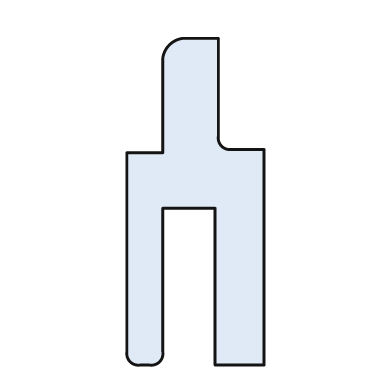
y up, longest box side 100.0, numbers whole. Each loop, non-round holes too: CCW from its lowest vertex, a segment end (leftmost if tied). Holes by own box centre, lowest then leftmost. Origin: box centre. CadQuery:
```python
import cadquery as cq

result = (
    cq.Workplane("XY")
    .moveTo(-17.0, -50.0)
    .lineTo(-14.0, -50.0)
    .threePointArc((-11.0, -49.0), (-10.0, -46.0))
    .lineTo(-10.0, -2.0)
    .lineTo(6.0, -2.0)
    .lineTo(6.0, -50.0)
    .lineTo(21.0, -50.0)
    .lineTo(21.0, 16.0)
    .lineTo(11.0, 16.0)
    .threePointArc((8.0, 17.0), (7.0, 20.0))
    .lineTo(7.0, 50.0)
    .lineTo(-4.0, 50.0)
    .threePointArc((-8.0, 48.0), (-10.0, 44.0))
    .lineTo(-10.0, 15.0)
    .lineTo(-21.0, 15.0)
    .lineTo(-21.0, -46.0)
    .threePointArc((-20.0, -49.0), (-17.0, -50.0))
    .close()
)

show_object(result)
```